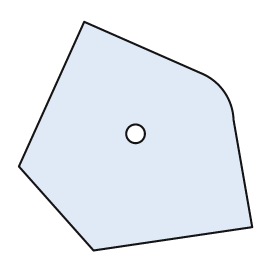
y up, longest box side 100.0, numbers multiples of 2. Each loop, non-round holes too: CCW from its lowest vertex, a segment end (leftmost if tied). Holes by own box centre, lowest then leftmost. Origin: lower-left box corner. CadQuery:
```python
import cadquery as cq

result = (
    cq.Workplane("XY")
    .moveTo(32.0, 0.0)
    .lineTo(100.0, 10.0)
    .lineTo(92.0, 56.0)
    .threePointArc((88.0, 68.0), (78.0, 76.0))
    .lineTo(28.0, 98.0)
    .lineTo(0.0, 36.0)
    .close()
    .moveTo(50.0, 50.0)
    .circle(4.0)
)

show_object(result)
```